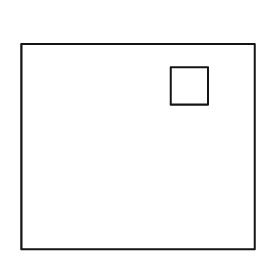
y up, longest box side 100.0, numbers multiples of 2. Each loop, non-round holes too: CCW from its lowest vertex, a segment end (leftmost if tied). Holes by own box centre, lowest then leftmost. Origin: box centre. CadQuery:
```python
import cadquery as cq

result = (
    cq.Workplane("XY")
    .moveTo(-50.0, -44.0)
    .lineTo(50.0, -44.0)
    .lineTo(50.0, 44.0)
    .lineTo(-50.0, 44.0)
    .close()
    .moveTo(14.0, 18.0)
    .lineTo(30.0, 18.0)
    .lineTo(30.0, 34.0)
    .lineTo(14.0, 34.0)
    .close()
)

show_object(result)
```